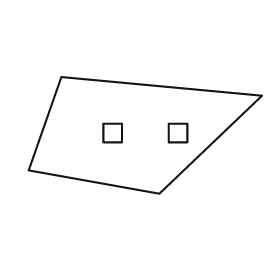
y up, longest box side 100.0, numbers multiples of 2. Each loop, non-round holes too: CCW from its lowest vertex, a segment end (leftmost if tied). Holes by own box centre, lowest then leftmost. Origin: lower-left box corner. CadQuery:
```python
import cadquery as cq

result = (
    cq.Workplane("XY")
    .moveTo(56.0, 0.0)
    .lineTo(100.0, 42.0)
    .lineTo(14.0, 50.0)
    .lineTo(0.0, 10.0)
    .close()
    .moveTo(32.0, 22.0)
    .lineTo(40.0, 22.0)
    .lineTo(40.0, 30.0)
    .lineTo(32.0, 30.0)
    .close()
    .moveTo(60.0, 22.0)
    .lineTo(68.0, 22.0)
    .lineTo(68.0, 30.0)
    .lineTo(60.0, 30.0)
    .close()
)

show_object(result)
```